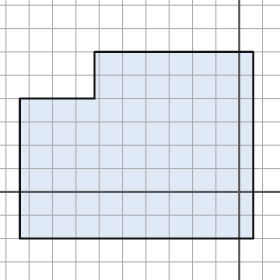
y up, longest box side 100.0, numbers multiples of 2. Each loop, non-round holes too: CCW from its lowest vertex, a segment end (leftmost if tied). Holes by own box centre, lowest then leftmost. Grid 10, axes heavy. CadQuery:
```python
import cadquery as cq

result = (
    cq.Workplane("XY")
    .moveTo(-94.0, -20.0)
    .lineTo(6.0, -20.0)
    .lineTo(6.0, 60.0)
    .lineTo(-62.0, 60.0)
    .lineTo(-62.0, 40.0)
    .lineTo(-94.0, 40.0)
    .close()
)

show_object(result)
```